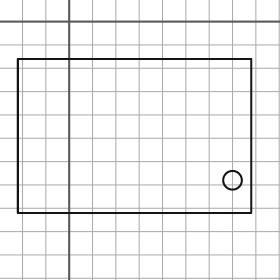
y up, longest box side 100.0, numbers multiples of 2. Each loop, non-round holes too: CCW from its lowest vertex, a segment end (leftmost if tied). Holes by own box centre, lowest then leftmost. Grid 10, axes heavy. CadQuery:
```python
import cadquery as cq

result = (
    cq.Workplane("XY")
    .moveTo(-22.0, -82.0)
    .lineTo(78.0, -82.0)
    .lineTo(78.0, -16.0)
    .lineTo(-22.0, -16.0)
    .close()
    .moveTo(70.0, -68.0)
    .circle(4.0)
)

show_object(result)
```